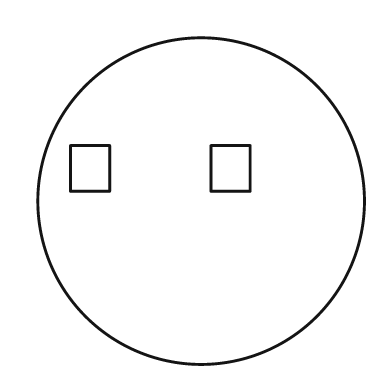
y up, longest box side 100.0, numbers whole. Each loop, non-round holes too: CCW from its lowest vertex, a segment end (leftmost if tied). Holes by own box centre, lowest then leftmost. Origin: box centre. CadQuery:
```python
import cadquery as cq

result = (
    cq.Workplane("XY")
    .moveTo(0.0, 0.0)
    .circle(50.0)
    .moveTo(-40.0, 3.0)
    .lineTo(-28.0, 3.0)
    .lineTo(-28.0, 17.0)
    .lineTo(-40.0, 17.0)
    .close()
    .moveTo(3.0, 3.0)
    .lineTo(15.0, 3.0)
    .lineTo(15.0, 17.0)
    .lineTo(3.0, 17.0)
    .close()
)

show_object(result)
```